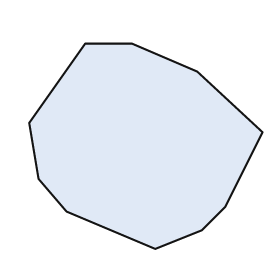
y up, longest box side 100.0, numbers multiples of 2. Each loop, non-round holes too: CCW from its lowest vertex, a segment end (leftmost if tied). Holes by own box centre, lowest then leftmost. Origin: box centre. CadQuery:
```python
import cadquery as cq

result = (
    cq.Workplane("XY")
    .moveTo(4.0, -44.0)
    .lineTo(24.0, -36.0)
    .lineTo(34.0, -26.0)
    .lineTo(50.0, 6.0)
    .lineTo(22.0, 32.0)
    .lineTo(-6.0, 44.0)
    .lineTo(-26.0, 44.0)
    .lineTo(-50.0, 10.0)
    .lineTo(-46.0, -14.0)
    .lineTo(-34.0, -28.0)
    .close()
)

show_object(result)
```